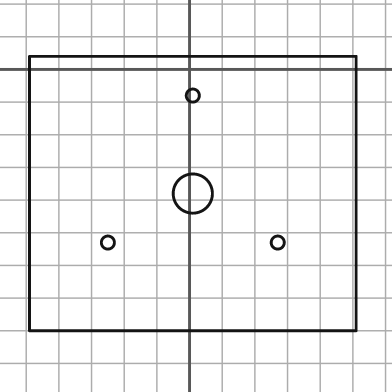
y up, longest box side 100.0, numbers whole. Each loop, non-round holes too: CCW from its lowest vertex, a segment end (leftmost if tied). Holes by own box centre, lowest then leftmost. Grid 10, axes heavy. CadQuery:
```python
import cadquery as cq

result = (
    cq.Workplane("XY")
    .moveTo(-49.0, -80.0)
    .lineTo(51.0, -80.0)
    .lineTo(51.0, 4.0)
    .lineTo(-49.0, 4.0)
    .close()
    .moveTo(-25.0, -53.0)
    .circle(2.0)
    .moveTo(27.0, -53.0)
    .circle(2.0)
    .moveTo(1.0, -38.0)
    .circle(6.0)
    .moveTo(1.0, -8.0)
    .circle(2.0)
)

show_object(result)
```